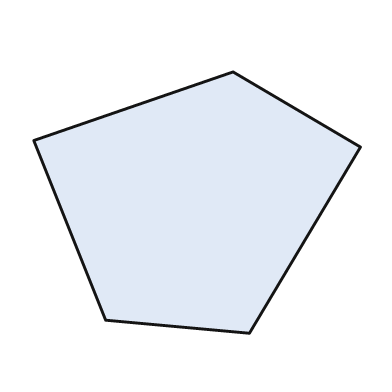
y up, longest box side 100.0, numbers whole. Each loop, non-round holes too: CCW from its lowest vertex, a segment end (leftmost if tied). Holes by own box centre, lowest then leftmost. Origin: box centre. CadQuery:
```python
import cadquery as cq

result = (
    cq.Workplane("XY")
    .moveTo(16.0, -40.0)
    .lineTo(50.0, 17.0)
    .lineTo(11.0, 40.0)
    .lineTo(-50.0, 19.0)
    .lineTo(-28.0, -36.0)
    .close()
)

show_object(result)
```